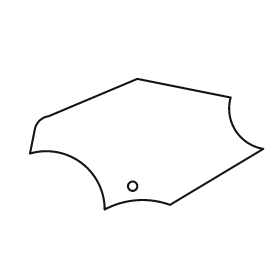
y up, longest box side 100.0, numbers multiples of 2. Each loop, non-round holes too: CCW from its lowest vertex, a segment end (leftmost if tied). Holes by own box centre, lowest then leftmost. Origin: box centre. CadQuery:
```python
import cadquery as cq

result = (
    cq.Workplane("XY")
    .moveTo(-18.0, -28.0)
    .threePointArc((-4.0, -24.0), (10.0, -26.0))
    .lineTo(50.0, -2.0)
    .threePointArc((38.0, 6.0), (36.0, 20.0))
    .lineTo(-4.0, 28.0)
    .lineTo(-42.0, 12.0)
    .threePointArc((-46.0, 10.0), (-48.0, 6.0))
    .lineTo(-50.0, -4.0)
    .threePointArc((-28.0, -8.0), (-18.0, -28.0))
    .close()
    .moveTo(-6.0, -18.0)
    .circle(2.0)
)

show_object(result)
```